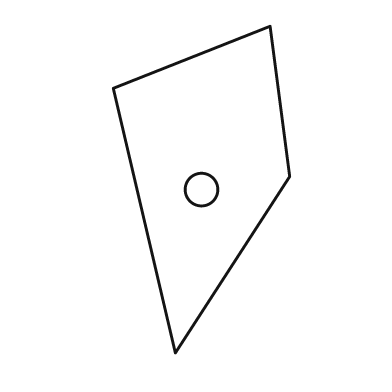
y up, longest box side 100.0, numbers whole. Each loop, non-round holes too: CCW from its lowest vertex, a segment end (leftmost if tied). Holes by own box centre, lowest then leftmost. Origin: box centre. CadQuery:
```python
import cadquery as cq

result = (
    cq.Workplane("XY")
    .moveTo(-8.0, -50.0)
    .lineTo(27.0, 4.0)
    .lineTo(21.0, 50.0)
    .lineTo(-27.0, 31.0)
    .close()
    .moveTo(0.0, 0.0)
    .circle(5.0)
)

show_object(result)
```